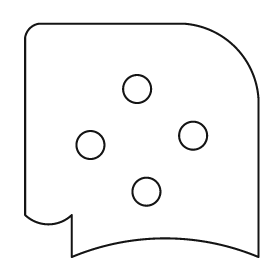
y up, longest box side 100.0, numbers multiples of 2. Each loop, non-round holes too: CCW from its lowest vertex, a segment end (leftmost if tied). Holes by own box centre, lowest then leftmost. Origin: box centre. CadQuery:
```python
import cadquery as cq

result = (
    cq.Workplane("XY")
    .moveTo(-30.0, -50.0)
    .threePointArc((10.0, -42.0), (50.0, -50.0))
    .lineTo(50.0, 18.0)
    .threePointArc((40.0, 40.0), (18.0, 50.0))
    .lineTo(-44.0, 50.0)
    .threePointArc((-48.0, 48.0), (-50.0, 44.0))
    .lineTo(-50.0, -32.0)
    .threePointArc((-40.0, -36.0), (-30.0, -32.0))
    .close()
    .moveTo(2.0, -22.0)
    .circle(6.0)
    .moveTo(-22.0, -2.0)
    .circle(6.0)
    .moveTo(22.0, 2.0)
    .circle(6.0)
    .moveTo(-2.0, 22.0)
    .circle(6.0)
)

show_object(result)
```